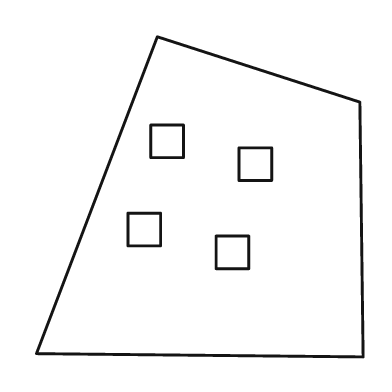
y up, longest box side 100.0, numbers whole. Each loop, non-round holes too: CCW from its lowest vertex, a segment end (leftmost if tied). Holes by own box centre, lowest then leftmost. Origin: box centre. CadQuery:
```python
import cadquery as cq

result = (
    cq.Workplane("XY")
    .moveTo(50.0, -49.0)
    .lineTo(49.0, 29.0)
    .lineTo(-13.0, 49.0)
    .lineTo(-50.0, -48.0)
    .close()
    .moveTo(5.0, -22.0)
    .lineTo(15.0, -22.0)
    .lineTo(15.0, -12.0)
    .lineTo(5.0, -12.0)
    .close()
    .moveTo(-22.0, -15.0)
    .lineTo(-12.0, -15.0)
    .lineTo(-12.0, -5.0)
    .lineTo(-22.0, -5.0)
    .close()
    .moveTo(12.0, 5.0)
    .lineTo(22.0, 5.0)
    .lineTo(22.0, 15.0)
    .lineTo(12.0, 15.0)
    .close()
    .moveTo(-15.0, 12.0)
    .lineTo(-5.0, 12.0)
    .lineTo(-5.0, 22.0)
    .lineTo(-15.0, 22.0)
    .close()
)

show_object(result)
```